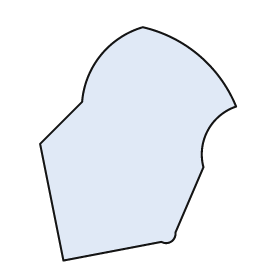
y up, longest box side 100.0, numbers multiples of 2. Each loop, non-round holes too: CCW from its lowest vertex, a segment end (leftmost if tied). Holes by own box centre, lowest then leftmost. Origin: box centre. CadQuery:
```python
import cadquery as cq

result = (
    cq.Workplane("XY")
    .moveTo(-32.0, -50.0)
    .lineTo(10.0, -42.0)
    .threePointArc((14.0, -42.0), (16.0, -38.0))
    .lineTo(28.0, -10.0)
    .threePointArc((30.0, 6.0), (42.0, 16.0))
    .threePointArc((26.0, 38.0), (2.0, 50.0))
    .threePointArc((-16.0, 38.0), (-24.0, 18.0))
    .lineTo(-42.0, 0.0)
    .close()
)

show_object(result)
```